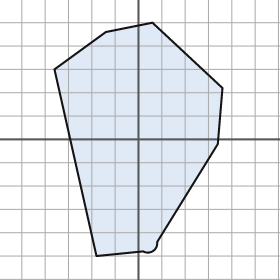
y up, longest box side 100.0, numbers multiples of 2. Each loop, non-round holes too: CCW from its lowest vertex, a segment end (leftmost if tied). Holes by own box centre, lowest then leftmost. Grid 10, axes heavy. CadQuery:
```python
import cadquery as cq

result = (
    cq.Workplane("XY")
    .moveTo(-18.0, -50.0)
    .lineTo(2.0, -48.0)
    .threePointArc((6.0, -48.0), (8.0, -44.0))
    .lineTo(34.0, -2.0)
    .lineTo(36.0, 22.0)
    .lineTo(6.0, 50.0)
    .lineTo(-14.0, 46.0)
    .lineTo(-36.0, 30.0)
    .close()
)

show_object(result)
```